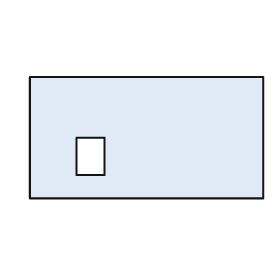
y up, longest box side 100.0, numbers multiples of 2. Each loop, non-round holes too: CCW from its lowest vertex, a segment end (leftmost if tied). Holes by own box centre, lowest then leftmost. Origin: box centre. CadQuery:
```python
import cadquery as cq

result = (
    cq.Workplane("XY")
    .moveTo(-50.0, -26.0)
    .lineTo(50.0, -26.0)
    .lineTo(50.0, 26.0)
    .lineTo(-50.0, 26.0)
    .close()
    .moveTo(-30.0, -16.0)
    .lineTo(-18.0, -16.0)
    .lineTo(-18.0, 0.0)
    .lineTo(-30.0, 0.0)
    .close()
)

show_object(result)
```